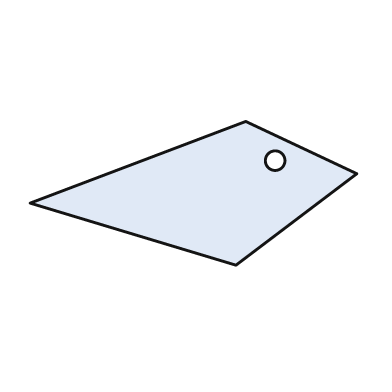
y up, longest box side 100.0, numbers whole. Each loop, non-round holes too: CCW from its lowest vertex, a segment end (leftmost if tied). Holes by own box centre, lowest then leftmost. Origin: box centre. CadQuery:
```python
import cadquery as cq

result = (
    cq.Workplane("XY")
    .moveTo(13.0, -22.0)
    .lineTo(50.0, 6.0)
    .lineTo(16.0, 22.0)
    .lineTo(-50.0, -3.0)
    .close()
    .moveTo(25.0, 10.0)
    .circle(3.0)
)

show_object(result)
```